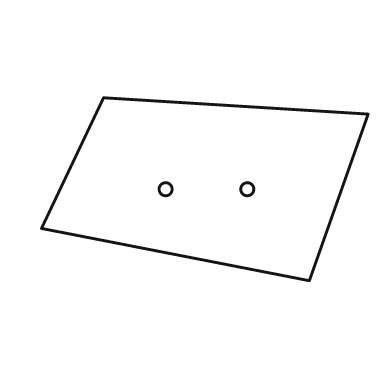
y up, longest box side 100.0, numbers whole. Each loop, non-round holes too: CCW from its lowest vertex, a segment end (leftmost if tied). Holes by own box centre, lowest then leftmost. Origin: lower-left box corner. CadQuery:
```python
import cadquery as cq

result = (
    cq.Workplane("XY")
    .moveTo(82.0, 0.0)
    .lineTo(100.0, 51.0)
    .lineTo(19.0, 56.0)
    .lineTo(0.0, 16.0)
    .close()
    .moveTo(38.0, 28.0)
    .circle(2.0)
    .moveTo(63.0, 28.0)
    .circle(2.0)
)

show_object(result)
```